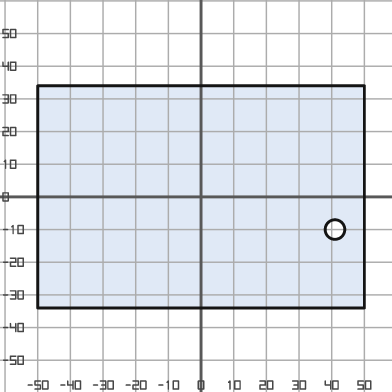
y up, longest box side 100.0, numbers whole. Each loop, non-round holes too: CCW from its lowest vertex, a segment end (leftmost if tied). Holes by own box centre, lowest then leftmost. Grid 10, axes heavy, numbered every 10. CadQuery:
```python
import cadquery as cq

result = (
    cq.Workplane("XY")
    .moveTo(-50.0, -34.0)
    .lineTo(50.0, -34.0)
    .lineTo(50.0, 34.0)
    .lineTo(-50.0, 34.0)
    .close()
    .moveTo(41.0, -10.0)
    .circle(3.0)
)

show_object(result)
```